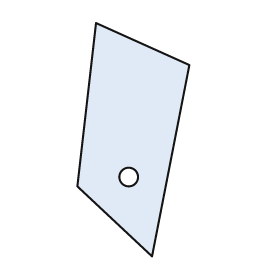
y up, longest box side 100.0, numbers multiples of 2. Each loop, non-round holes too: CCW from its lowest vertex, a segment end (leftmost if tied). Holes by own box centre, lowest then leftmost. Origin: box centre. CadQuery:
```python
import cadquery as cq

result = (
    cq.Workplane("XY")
    .moveTo(8.0, -50.0)
    .lineTo(24.0, 32.0)
    .lineTo(-16.0, 50.0)
    .lineTo(-24.0, -20.0)
    .close()
    .moveTo(-2.0, -16.0)
    .circle(4.0)
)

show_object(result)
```